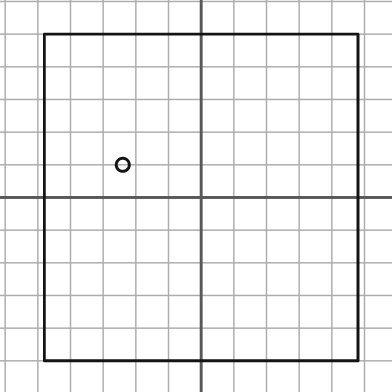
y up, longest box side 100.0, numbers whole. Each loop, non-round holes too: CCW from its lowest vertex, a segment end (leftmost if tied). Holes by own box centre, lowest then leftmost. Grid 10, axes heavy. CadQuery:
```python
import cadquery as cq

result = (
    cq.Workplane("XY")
    .moveTo(-48.0, -50.0)
    .lineTo(48.0, -50.0)
    .lineTo(48.0, 50.0)
    .lineTo(-48.0, 50.0)
    .close()
    .moveTo(-24.0, 10.0)
    .circle(2.0)
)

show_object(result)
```